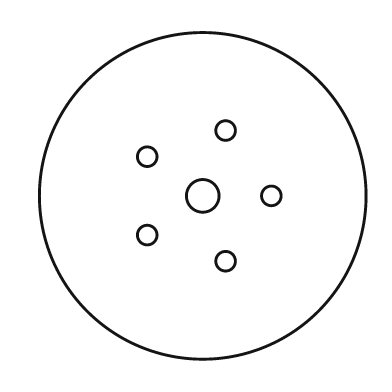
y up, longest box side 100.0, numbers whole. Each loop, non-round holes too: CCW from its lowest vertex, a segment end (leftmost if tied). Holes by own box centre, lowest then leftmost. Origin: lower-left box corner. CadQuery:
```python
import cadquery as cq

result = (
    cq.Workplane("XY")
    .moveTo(50.0, 50.0)
    .circle(50.0)
    .moveTo(57.0, 30.0)
    .circle(3.0)
    .moveTo(33.0, 38.0)
    .circle(3.0)
    .moveTo(50.0, 50.0)
    .circle(5.0)
    .moveTo(71.0, 50.0)
    .circle(3.0)
    .moveTo(33.0, 62.0)
    .circle(3.0)
    .moveTo(57.0, 70.0)
    .circle(3.0)
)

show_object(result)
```